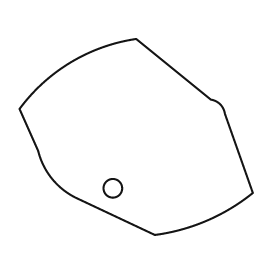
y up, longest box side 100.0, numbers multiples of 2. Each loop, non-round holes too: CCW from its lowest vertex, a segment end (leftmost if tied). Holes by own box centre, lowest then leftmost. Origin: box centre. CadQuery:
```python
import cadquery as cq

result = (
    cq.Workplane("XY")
    .moveTo(8.0, -42.0)
    .threePointArc((30.0, -36.0), (50.0, -24.0))
    .lineTo(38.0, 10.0)
    .threePointArc((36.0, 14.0), (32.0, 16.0))
    .lineTo(0.0, 42.0)
    .threePointArc((-28.0, 32.0), (-50.0, 12.0))
    .lineTo(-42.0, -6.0)
    .threePointArc((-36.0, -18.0), (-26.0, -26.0))
    .close()
    .moveTo(-10.0, -22.0)
    .circle(4.0)
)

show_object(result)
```